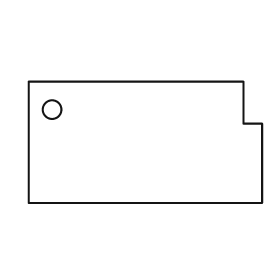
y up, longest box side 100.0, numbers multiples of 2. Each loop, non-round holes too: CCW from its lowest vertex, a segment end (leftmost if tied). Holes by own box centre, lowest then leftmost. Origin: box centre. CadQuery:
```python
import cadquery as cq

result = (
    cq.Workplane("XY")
    .moveTo(-50.0, -26.0)
    .lineTo(50.0, -26.0)
    .lineTo(50.0, 8.0)
    .lineTo(42.0, 8.0)
    .lineTo(42.0, 26.0)
    .lineTo(-50.0, 26.0)
    .close()
    .moveTo(-40.0, 14.0)
    .circle(4.0)
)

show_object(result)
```